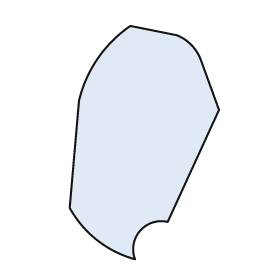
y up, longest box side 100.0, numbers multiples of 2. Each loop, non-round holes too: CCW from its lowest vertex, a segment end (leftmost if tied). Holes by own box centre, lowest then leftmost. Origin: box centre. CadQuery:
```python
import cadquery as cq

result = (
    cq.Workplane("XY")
    .moveTo(-4.0, -50.0)
    .threePointArc((-2.0, -38.0), (10.0, -34.0))
    .lineTo(32.0, 14.0)
    .lineTo(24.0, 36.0)
    .threePointArc((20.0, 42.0), (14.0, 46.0))
    .lineTo(-6.0, 50.0)
    .threePointArc((-20.0, 36.0), (-28.0, 18.0))
    .lineTo(-32.0, -28.0)
    .threePointArc((-20.0, -42.0), (-4.0, -50.0))
    .close()
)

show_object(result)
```